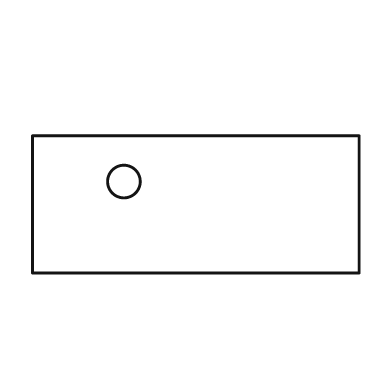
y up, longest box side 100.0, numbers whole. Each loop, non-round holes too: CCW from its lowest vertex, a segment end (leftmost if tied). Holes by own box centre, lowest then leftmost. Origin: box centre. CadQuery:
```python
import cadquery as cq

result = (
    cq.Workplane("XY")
    .moveTo(-50.0, -21.0)
    .lineTo(50.0, -21.0)
    .lineTo(50.0, 21.0)
    .lineTo(-50.0, 21.0)
    .close()
    .moveTo(-22.0, 7.0)
    .circle(5.0)
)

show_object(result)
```